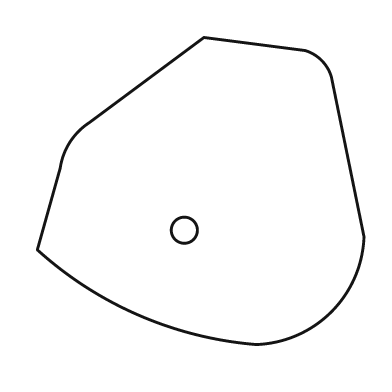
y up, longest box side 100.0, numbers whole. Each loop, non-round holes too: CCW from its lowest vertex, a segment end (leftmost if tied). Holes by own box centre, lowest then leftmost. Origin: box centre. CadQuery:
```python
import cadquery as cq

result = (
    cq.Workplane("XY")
    .moveTo(17.0, -47.0)
    .threePointArc((40.0, -37.0), (50.0, -14.0))
    .lineTo(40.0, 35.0)
    .threePointArc((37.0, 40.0), (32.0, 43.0))
    .lineTo(1.0, 47.0)
    .lineTo(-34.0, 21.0)
    .threePointArc((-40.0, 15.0), (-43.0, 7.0))
    .lineTo(-50.0, -18.0)
    .threePointArc((-19.0, -38.0), (17.0, -47.0))
    .close()
    .moveTo(-5.0, -12.0)
    .circle(4.0)
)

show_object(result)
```